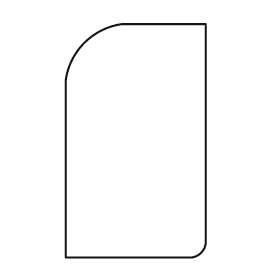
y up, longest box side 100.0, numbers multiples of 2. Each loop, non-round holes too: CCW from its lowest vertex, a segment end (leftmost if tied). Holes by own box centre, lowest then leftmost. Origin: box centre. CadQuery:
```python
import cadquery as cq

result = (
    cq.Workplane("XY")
    .moveTo(-30.0, -50.0)
    .lineTo(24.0, -50.0)
    .threePointArc((28.0, -48.0), (30.0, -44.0))
    .lineTo(30.0, 50.0)
    .lineTo(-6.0, 50.0)
    .threePointArc((-22.0, 42.0), (-30.0, 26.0))
    .close()
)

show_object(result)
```